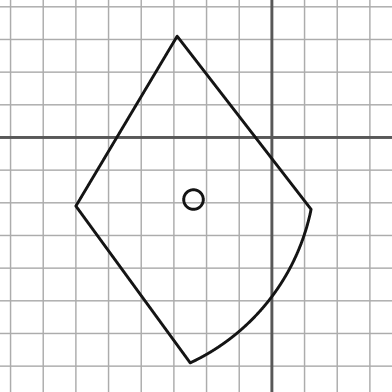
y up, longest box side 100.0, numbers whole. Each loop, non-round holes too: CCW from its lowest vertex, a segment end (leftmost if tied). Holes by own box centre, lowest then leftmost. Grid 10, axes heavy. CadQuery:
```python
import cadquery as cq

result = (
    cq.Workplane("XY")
    .moveTo(-25.0, -69.0)
    .threePointArc((-1.0, -50.0), (12.0, -22.0))
    .lineTo(-29.0, 31.0)
    .lineTo(-60.0, -21.0)
    .close()
    .moveTo(-24.0, -19.0)
    .circle(3.0)
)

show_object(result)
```